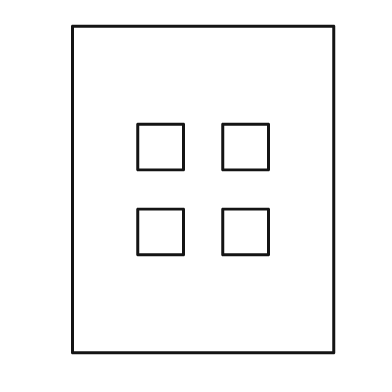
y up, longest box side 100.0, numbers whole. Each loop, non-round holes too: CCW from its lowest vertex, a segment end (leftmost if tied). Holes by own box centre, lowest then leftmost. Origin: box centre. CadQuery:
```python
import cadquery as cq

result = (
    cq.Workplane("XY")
    .moveTo(-40.0, -50.0)
    .lineTo(40.0, -50.0)
    .lineTo(40.0, 50.0)
    .lineTo(-40.0, 50.0)
    .close()
    .moveTo(-20.0, -20.0)
    .lineTo(-6.0, -20.0)
    .lineTo(-6.0, -6.0)
    .lineTo(-20.0, -6.0)
    .close()
    .moveTo(6.0, -20.0)
    .lineTo(20.0, -20.0)
    .lineTo(20.0, -6.0)
    .lineTo(6.0, -6.0)
    .close()
    .moveTo(-20.0, 6.0)
    .lineTo(-6.0, 6.0)
    .lineTo(-6.0, 20.0)
    .lineTo(-20.0, 20.0)
    .close()
    .moveTo(6.0, 6.0)
    .lineTo(20.0, 6.0)
    .lineTo(20.0, 20.0)
    .lineTo(6.0, 20.0)
    .close()
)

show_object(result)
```